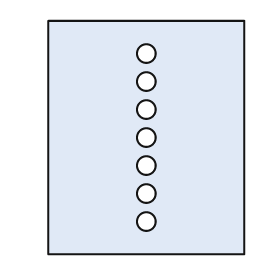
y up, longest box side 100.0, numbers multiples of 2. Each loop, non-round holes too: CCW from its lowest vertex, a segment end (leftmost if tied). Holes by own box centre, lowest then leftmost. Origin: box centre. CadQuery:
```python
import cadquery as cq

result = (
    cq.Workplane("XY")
    .moveTo(-42.0, -50.0)
    .lineTo(42.0, -50.0)
    .lineTo(42.0, 50.0)
    .lineTo(-42.0, 50.0)
    .close()
    .moveTo(0.0, -36.0)
    .circle(4.0)
    .moveTo(0.0, -24.0)
    .circle(4.0)
    .moveTo(0.0, -12.0)
    .circle(4.0)
    .moveTo(0.0, 0.0)
    .circle(4.0)
    .moveTo(0.0, 12.0)
    .circle(4.0)
    .moveTo(0.0, 24.0)
    .circle(4.0)
    .moveTo(0.0, 36.0)
    .circle(4.0)
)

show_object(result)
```